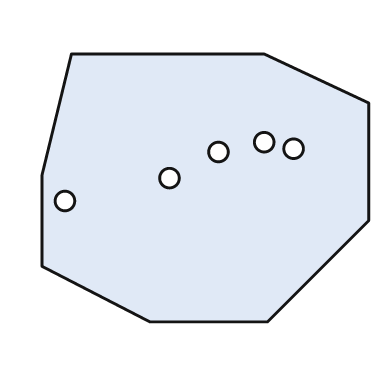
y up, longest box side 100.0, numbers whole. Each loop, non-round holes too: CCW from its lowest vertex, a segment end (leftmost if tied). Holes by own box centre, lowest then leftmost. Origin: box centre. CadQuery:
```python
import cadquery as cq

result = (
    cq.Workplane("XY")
    .moveTo(-17.0, -41.0)
    .lineTo(19.0, -41.0)
    .lineTo(50.0, -10.0)
    .lineTo(50.0, 26.0)
    .lineTo(18.0, 41.0)
    .lineTo(-41.0, 41.0)
    .lineTo(-50.0, 4.0)
    .lineTo(-50.0, -24.0)
    .close()
    .moveTo(-43.0, -4.0)
    .circle(3.0)
    .moveTo(-11.0, 3.0)
    .circle(3.0)
    .moveTo(4.0, 11.0)
    .circle(3.0)
    .moveTo(27.0, 12.0)
    .circle(3.0)
    .moveTo(18.0, 14.0)
    .circle(3.0)
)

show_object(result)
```